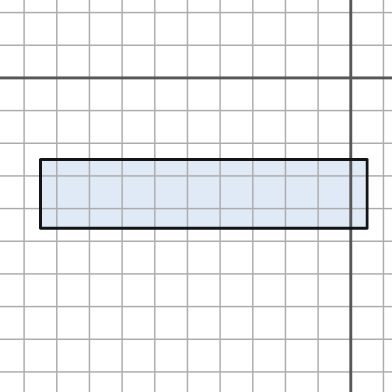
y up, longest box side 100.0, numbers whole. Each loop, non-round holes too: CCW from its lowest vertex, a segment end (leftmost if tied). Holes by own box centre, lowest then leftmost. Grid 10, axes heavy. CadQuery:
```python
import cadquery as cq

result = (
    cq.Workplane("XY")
    .moveTo(-95.0, -46.0)
    .lineTo(5.0, -46.0)
    .lineTo(5.0, -25.0)
    .lineTo(-95.0, -25.0)
    .close()
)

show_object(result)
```